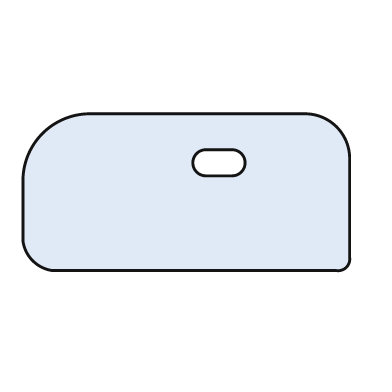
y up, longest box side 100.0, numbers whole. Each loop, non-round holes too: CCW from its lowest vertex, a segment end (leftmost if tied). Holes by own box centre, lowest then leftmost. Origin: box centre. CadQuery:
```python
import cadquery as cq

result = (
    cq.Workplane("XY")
    .moveTo(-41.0, -24.0)
    .lineTo(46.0, -24.0)
    .threePointArc((49.0, -23.0), (50.0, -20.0))
    .lineTo(50.0, 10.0)
    .threePointArc((46.0, 20.0), (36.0, 24.0))
    .lineTo(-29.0, 24.0)
    .threePointArc((-44.0, 18.0), (-50.0, 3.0))
    .lineTo(-50.0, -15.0)
    .threePointArc((-47.0, -21.0), (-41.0, -24.0))
    .close()
    .moveTo(6.0, 5.0)
    .lineTo(14.0, 5.0)
    .threePointArc((18.0, 9.0), (14.0, 13.0))
    .lineTo(6.0, 13.0)
    .threePointArc((2.0, 9.0), (6.0, 5.0))
    .close()
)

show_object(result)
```